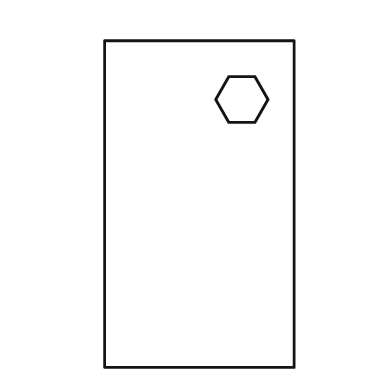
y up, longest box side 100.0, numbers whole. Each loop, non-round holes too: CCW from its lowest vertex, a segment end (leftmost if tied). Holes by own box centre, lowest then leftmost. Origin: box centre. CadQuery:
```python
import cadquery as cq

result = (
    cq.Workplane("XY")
    .moveTo(-29.0, -50.0)
    .lineTo(29.0, -50.0)
    .lineTo(29.0, 50.0)
    .lineTo(-29.0, 50.0)
    .close()
    .moveTo(9.0, 25.0)
    .lineTo(17.0, 25.0)
    .lineTo(21.0, 32.0)
    .lineTo(17.0, 39.0)
    .lineTo(9.0, 39.0)
    .lineTo(5.0, 32.0)
    .close()
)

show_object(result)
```